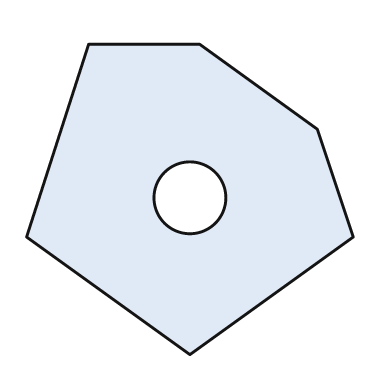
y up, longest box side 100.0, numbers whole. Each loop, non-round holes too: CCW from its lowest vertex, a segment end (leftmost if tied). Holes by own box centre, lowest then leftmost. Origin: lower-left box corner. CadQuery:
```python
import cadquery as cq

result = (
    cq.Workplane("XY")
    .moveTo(50.0, 0.0)
    .lineTo(100.0, 36.0)
    .lineTo(89.0, 69.0)
    .lineTo(53.0, 95.0)
    .lineTo(19.0, 95.0)
    .lineTo(0.0, 36.0)
    .close()
    .moveTo(50.0, 48.0)
    .circle(11.0)
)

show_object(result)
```